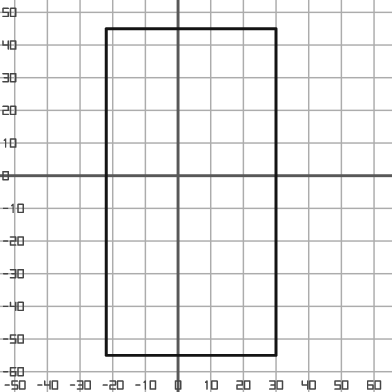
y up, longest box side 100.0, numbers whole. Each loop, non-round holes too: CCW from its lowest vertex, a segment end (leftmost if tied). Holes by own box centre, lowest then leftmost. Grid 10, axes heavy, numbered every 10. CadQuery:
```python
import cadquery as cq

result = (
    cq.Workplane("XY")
    .moveTo(-22.0, -55.0)
    .lineTo(30.0, -55.0)
    .lineTo(30.0, 45.0)
    .lineTo(-22.0, 45.0)
    .close()
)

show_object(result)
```